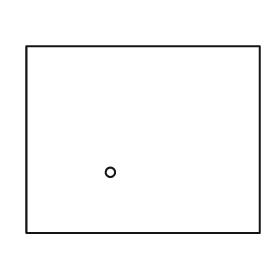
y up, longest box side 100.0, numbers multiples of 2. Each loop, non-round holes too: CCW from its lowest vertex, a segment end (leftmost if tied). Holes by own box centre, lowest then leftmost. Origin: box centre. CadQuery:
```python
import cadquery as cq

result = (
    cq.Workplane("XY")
    .moveTo(-50.0, -40.0)
    .lineTo(50.0, -40.0)
    .lineTo(50.0, 40.0)
    .lineTo(-50.0, 40.0)
    .close()
    .moveTo(-14.0, -14.0)
    .circle(2.0)
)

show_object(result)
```